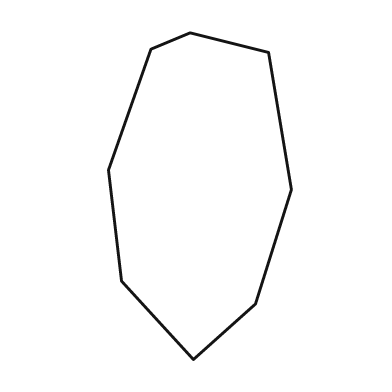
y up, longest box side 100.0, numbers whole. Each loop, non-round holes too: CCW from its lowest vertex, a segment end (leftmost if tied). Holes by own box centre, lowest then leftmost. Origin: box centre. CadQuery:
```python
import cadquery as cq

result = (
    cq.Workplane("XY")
    .moveTo(-2.0, -50.0)
    .lineTo(17.0, -33.0)
    .lineTo(28.0, 2.0)
    .lineTo(21.0, 44.0)
    .lineTo(-3.0, 50.0)
    .lineTo(-15.0, 45.0)
    .lineTo(-28.0, 8.0)
    .lineTo(-24.0, -26.0)
    .close()
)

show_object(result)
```